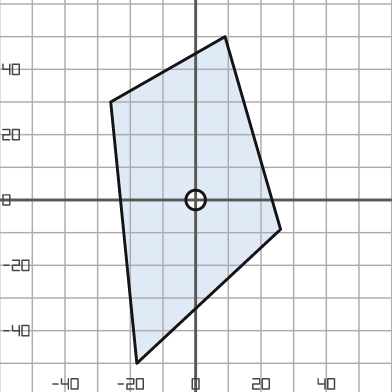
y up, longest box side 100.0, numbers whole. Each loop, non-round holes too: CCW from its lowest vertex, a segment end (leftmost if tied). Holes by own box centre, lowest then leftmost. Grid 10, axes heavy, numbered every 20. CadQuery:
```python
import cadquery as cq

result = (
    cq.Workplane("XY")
    .moveTo(-18.0, -50.0)
    .lineTo(26.0, -9.0)
    .lineTo(9.0, 50.0)
    .lineTo(-26.0, 30.0)
    .close()
    .moveTo(0.0, 0.0)
    .circle(3.0)
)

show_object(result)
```